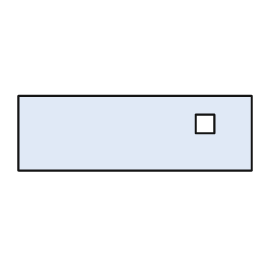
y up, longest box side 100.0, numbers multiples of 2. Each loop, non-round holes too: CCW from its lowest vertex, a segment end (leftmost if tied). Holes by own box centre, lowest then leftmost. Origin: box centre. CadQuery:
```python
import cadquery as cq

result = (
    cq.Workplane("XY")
    .moveTo(-50.0, -16.0)
    .lineTo(50.0, -16.0)
    .lineTo(50.0, 16.0)
    .lineTo(-50.0, 16.0)
    .close()
    .moveTo(26.0, 0.0)
    .lineTo(34.0, 0.0)
    .lineTo(34.0, 8.0)
    .lineTo(26.0, 8.0)
    .close()
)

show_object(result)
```